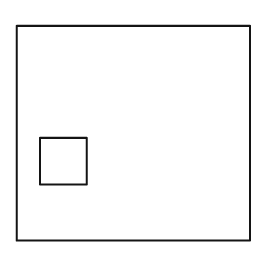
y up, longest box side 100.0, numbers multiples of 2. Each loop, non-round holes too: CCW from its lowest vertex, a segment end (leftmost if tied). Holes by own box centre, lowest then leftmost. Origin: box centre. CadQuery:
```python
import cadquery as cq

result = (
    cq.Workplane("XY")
    .moveTo(-50.0, -46.0)
    .lineTo(50.0, -46.0)
    .lineTo(50.0, 46.0)
    .lineTo(-50.0, 46.0)
    .close()
    .moveTo(-40.0, -22.0)
    .lineTo(-20.0, -22.0)
    .lineTo(-20.0, -2.0)
    .lineTo(-40.0, -2.0)
    .close()
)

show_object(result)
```